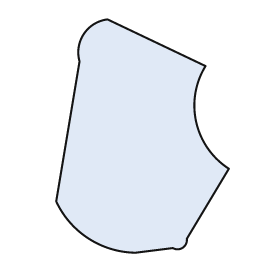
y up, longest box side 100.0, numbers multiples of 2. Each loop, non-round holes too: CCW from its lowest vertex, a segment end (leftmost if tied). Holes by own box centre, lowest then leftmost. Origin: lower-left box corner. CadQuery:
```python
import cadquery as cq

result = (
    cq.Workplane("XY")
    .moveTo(34.0, 0.0)
    .lineTo(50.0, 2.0)
    .threePointArc((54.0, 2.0), (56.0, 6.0))
    .lineTo(74.0, 36.0)
    .threePointArc((60.0, 56.0), (64.0, 80.0))
    .lineTo(22.0, 100.0)
    .threePointArc((12.0, 94.0), (10.0, 82.0))
    .lineTo(0.0, 22.0)
    .threePointArc((14.0, 6.0), (34.0, 0.0))
    .close()
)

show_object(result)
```